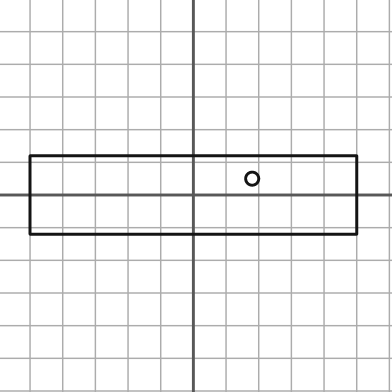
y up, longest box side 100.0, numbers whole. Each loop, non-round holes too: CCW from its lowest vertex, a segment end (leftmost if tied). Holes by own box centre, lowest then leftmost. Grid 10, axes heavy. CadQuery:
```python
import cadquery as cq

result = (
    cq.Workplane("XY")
    .moveTo(-50.0, -12.0)
    .lineTo(50.0, -12.0)
    .lineTo(50.0, 12.0)
    .lineTo(-50.0, 12.0)
    .close()
    .moveTo(18.0, 5.0)
    .circle(2.0)
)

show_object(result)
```